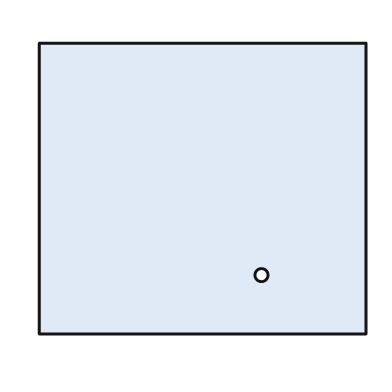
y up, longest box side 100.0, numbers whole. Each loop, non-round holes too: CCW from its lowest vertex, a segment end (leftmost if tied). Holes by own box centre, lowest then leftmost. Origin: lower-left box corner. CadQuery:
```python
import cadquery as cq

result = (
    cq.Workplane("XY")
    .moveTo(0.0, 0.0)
    .lineTo(100.0, 0.0)
    .lineTo(100.0, 89.0)
    .lineTo(0.0, 89.0)
    .close()
    .moveTo(68.0, 18.0)
    .circle(2.0)
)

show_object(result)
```